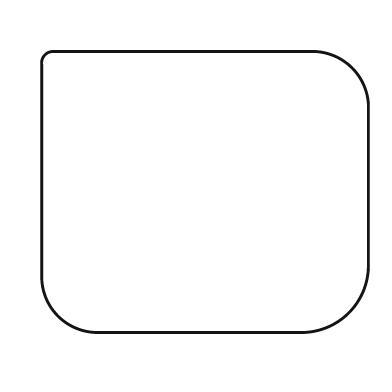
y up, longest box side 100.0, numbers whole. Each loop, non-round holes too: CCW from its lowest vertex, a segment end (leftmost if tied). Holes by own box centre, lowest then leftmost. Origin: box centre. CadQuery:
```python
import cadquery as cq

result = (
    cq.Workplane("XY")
    .moveTo(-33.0, -43.0)
    .lineTo(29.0, -43.0)
    .threePointArc((44.0, -37.0), (50.0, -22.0))
    .lineTo(50.0, 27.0)
    .threePointArc((45.0, 38.0), (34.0, 43.0))
    .lineTo(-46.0, 43.0)
    .threePointArc((-49.0, 42.0), (-50.0, 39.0))
    .lineTo(-50.0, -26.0)
    .threePointArc((-45.0, -38.0), (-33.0, -43.0))
    .close()
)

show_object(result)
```